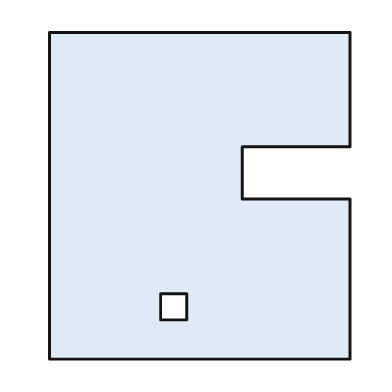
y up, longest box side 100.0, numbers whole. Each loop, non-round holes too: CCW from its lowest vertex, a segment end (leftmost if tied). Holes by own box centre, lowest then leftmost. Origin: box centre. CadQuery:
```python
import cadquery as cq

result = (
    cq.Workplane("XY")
    .moveTo(-46.0, -50.0)
    .lineTo(46.0, -50.0)
    .lineTo(46.0, -1.0)
    .lineTo(13.0, -1.0)
    .lineTo(13.0, 15.0)
    .lineTo(46.0, 15.0)
    .lineTo(46.0, 50.0)
    .lineTo(-46.0, 50.0)
    .close()
    .moveTo(-12.0, -38.0)
    .lineTo(-4.0, -38.0)
    .lineTo(-4.0, -30.0)
    .lineTo(-12.0, -30.0)
    .close()
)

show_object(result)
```